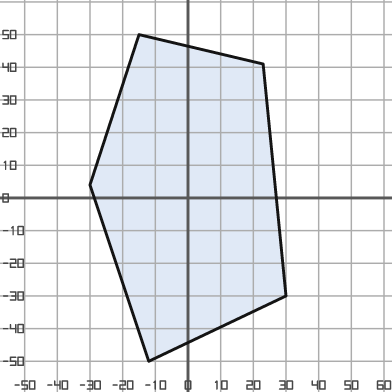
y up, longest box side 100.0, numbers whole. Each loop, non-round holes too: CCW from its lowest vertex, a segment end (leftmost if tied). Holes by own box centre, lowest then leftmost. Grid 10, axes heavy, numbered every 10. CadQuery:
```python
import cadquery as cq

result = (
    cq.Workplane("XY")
    .moveTo(-12.0, -50.0)
    .lineTo(30.0, -30.0)
    .lineTo(23.0, 41.0)
    .lineTo(-15.0, 50.0)
    .lineTo(-30.0, 4.0)
    .close()
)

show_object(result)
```